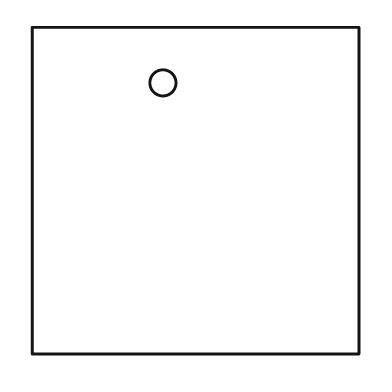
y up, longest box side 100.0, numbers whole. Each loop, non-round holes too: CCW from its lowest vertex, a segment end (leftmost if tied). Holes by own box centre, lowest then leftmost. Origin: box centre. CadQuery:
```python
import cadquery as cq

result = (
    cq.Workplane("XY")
    .moveTo(-50.0, -50.0)
    .lineTo(50.0, -50.0)
    .lineTo(50.0, 50.0)
    .lineTo(-50.0, 50.0)
    .close()
    .moveTo(-10.0, 33.0)
    .circle(4.0)
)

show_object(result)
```